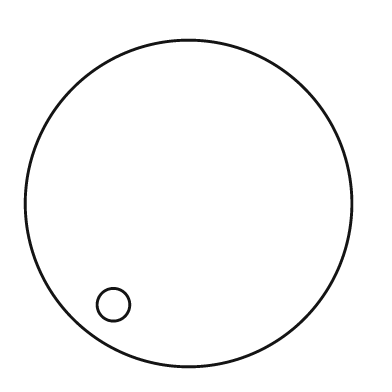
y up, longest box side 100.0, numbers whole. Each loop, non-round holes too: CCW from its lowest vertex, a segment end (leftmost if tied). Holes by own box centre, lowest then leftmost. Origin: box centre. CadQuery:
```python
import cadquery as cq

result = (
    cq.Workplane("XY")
    .moveTo(0.0, 0.0)
    .circle(50.0)
    .moveTo(-23.0, -31.0)
    .circle(5.0)
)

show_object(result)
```